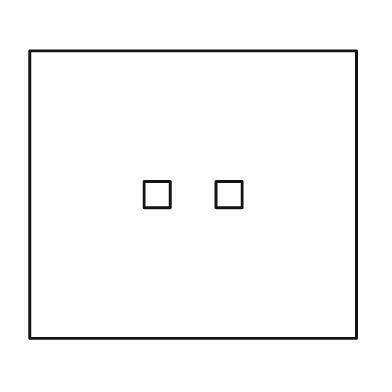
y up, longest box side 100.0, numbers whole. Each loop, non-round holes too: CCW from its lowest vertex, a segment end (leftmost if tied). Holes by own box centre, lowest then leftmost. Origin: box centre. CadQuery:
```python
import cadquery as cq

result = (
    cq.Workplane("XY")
    .moveTo(-50.0, -44.0)
    .lineTo(50.0, -44.0)
    .lineTo(50.0, 44.0)
    .lineTo(-50.0, 44.0)
    .close()
    .moveTo(-15.0, -4.0)
    .lineTo(-7.0, -4.0)
    .lineTo(-7.0, 4.0)
    .lineTo(-15.0, 4.0)
    .close()
    .moveTo(7.0, -4.0)
    .lineTo(15.0, -4.0)
    .lineTo(15.0, 4.0)
    .lineTo(7.0, 4.0)
    .close()
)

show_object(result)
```